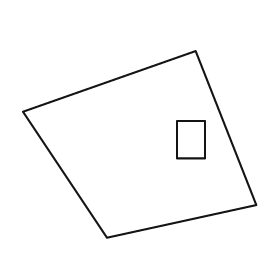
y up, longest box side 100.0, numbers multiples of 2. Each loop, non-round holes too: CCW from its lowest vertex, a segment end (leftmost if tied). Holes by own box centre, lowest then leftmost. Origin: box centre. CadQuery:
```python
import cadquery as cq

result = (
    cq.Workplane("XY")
    .moveTo(-14.0, -40.0)
    .lineTo(50.0, -26.0)
    .lineTo(24.0, 40.0)
    .lineTo(-50.0, 14.0)
    .close()
    .moveTo(16.0, -6.0)
    .lineTo(28.0, -6.0)
    .lineTo(28.0, 10.0)
    .lineTo(16.0, 10.0)
    .close()
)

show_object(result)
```